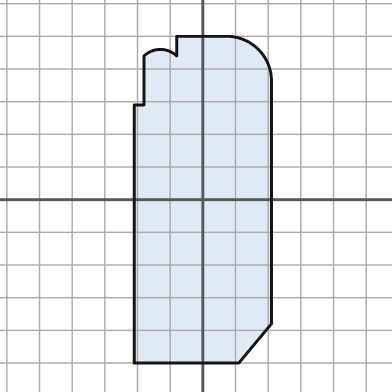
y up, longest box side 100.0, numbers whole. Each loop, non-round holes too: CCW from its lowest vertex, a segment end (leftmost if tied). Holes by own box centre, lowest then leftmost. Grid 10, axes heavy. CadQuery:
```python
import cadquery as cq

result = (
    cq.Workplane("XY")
    .moveTo(-21.0, -50.0)
    .lineTo(11.0, -50.0)
    .lineTo(21.0, -38.0)
    .lineTo(21.0, 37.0)
    .threePointArc((17.0, 46.0), (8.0, 50.0))
    .lineTo(-8.0, 50.0)
    .lineTo(-8.0, 44.0)
    .threePointArc((-13.0, 46.0), (-18.0, 44.0))
    .lineTo(-18.0, 29.0)
    .lineTo(-21.0, 29.0)
    .close()
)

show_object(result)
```